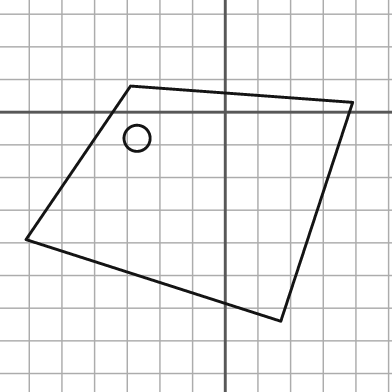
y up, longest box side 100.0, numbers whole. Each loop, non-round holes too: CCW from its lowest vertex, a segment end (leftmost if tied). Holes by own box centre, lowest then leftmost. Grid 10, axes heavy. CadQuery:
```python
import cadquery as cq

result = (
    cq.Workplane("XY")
    .moveTo(17.0, -64.0)
    .lineTo(39.0, 3.0)
    .lineTo(-29.0, 8.0)
    .lineTo(-61.0, -39.0)
    .close()
    .moveTo(-27.0, -8.0)
    .circle(4.0)
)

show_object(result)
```